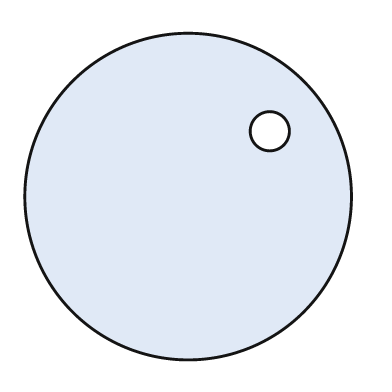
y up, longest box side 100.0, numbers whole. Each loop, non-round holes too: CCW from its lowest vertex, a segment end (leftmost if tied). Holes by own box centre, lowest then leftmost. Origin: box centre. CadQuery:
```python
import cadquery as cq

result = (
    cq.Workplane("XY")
    .moveTo(0.0, 0.0)
    .circle(50.0)
    .moveTo(25.0, 20.0)
    .circle(6.0)
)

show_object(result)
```